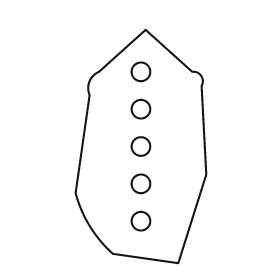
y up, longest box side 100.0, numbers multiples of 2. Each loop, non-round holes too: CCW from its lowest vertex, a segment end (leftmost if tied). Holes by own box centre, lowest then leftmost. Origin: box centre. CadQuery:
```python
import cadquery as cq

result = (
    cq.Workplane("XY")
    .moveTo(16.0, -50.0)
    .lineTo(28.0, -12.0)
    .lineTo(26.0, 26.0)
    .threePointArc((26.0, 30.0), (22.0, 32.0))
    .lineTo(2.0, 50.0)
    .lineTo(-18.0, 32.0)
    .threePointArc((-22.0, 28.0), (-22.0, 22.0))
    .lineTo(-28.0, -20.0)
    .threePointArc((-22.0, -34.0), (-12.0, -46.0))
    .close()
    .moveTo(0.0, -32.0)
    .circle(4.0)
    .moveTo(0.0, -16.0)
    .circle(4.0)
    .moveTo(0.0, 0.0)
    .circle(4.0)
    .moveTo(0.0, 16.0)
    .circle(4.0)
    .moveTo(0.0, 32.0)
    .circle(4.0)
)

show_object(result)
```